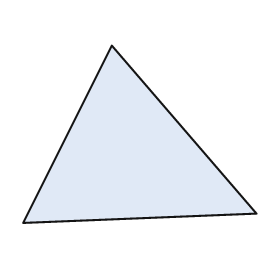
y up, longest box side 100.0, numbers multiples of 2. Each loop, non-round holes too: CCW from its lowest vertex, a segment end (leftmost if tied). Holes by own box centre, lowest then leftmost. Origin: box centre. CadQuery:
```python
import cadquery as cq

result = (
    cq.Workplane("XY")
    .moveTo(-50.0, -38.0)
    .lineTo(50.0, -34.0)
    .lineTo(-12.0, 38.0)
    .close()
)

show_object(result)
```